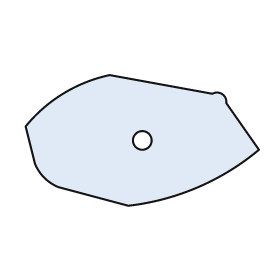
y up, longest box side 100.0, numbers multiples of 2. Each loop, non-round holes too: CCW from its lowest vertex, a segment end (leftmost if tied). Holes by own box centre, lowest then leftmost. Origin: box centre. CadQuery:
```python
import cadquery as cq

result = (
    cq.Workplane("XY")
    .moveTo(-6.0, -28.0)
    .threePointArc((24.0, -20.0), (50.0, -4.0))
    .lineTo(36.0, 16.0)
    .threePointArc((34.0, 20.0), (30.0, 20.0))
    .lineTo(-14.0, 28.0)
    .threePointArc((-34.0, 20.0), (-50.0, 6.0))
    .lineTo(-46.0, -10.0)
    .threePointArc((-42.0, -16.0), (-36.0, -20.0))
    .close()
    .moveTo(0.0, 0.0)
    .circle(4.0)
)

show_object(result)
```